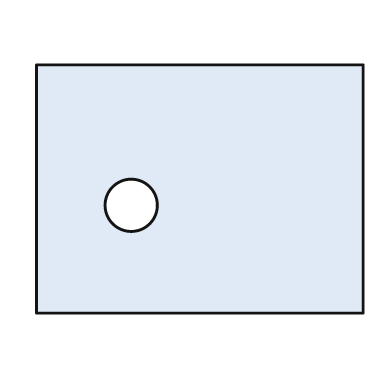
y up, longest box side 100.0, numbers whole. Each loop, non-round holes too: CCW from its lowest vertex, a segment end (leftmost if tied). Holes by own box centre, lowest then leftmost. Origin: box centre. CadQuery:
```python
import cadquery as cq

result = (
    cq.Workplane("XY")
    .moveTo(-50.0, -38.0)
    .lineTo(50.0, -38.0)
    .lineTo(50.0, 38.0)
    .lineTo(-50.0, 38.0)
    .close()
    .moveTo(-21.0, -5.0)
    .circle(8.0)
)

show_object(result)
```